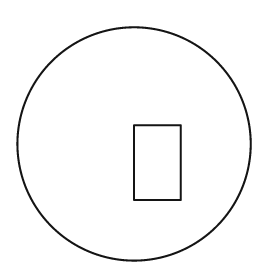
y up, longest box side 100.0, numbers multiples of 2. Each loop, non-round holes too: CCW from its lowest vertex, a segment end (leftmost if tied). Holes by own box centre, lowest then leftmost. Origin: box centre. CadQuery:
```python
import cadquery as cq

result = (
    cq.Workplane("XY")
    .moveTo(0.0, 0.0)
    .circle(50.0)
    .moveTo(0.0, -24.0)
    .lineTo(20.0, -24.0)
    .lineTo(20.0, 8.0)
    .lineTo(0.0, 8.0)
    .close()
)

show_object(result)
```